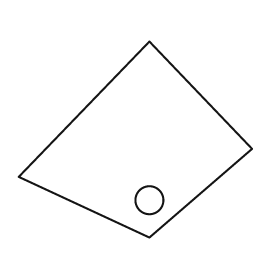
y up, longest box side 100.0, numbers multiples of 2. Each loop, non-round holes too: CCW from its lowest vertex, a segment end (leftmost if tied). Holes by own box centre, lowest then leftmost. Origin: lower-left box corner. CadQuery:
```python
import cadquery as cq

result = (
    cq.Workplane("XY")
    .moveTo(56.0, 0.0)
    .lineTo(100.0, 38.0)
    .lineTo(56.0, 84.0)
    .lineTo(0.0, 26.0)
    .close()
    .moveTo(56.0, 16.0)
    .circle(6.0)
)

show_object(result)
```